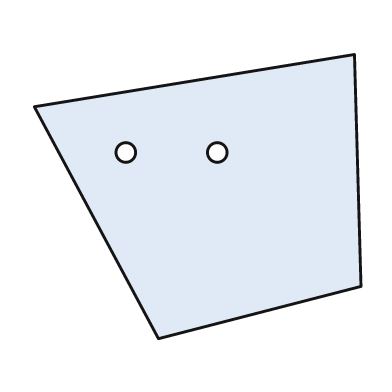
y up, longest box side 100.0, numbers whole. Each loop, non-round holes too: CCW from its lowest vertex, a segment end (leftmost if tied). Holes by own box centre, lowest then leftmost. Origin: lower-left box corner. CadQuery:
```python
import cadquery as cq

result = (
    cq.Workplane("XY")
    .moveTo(38.0, 0.0)
    .lineTo(100.0, 16.0)
    .lineTo(98.0, 87.0)
    .lineTo(0.0, 71.0)
    .close()
    .moveTo(28.0, 57.0)
    .circle(3.0)
    .moveTo(56.0, 57.0)
    .circle(3.0)
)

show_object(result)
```